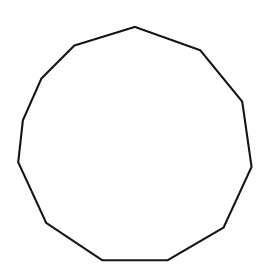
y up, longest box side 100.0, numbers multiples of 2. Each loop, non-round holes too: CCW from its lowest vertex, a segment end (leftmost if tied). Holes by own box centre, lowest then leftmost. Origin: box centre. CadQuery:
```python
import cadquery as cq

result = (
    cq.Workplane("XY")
    .moveTo(-14.0, -50.0)
    .lineTo(14.0, -50.0)
    .lineTo(38.0, -36.0)
    .lineTo(50.0, -10.0)
    .lineTo(46.0, 18.0)
    .lineTo(28.0, 40.0)
    .lineTo(0.0, 50.0)
    .lineTo(-26.0, 42.0)
    .lineTo(-40.0, 28.0)
    .lineTo(-48.0, 10.0)
    .lineTo(-50.0, -8.0)
    .lineTo(-38.0, -34.0)
    .close()
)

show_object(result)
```